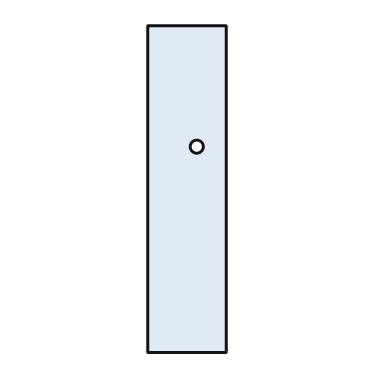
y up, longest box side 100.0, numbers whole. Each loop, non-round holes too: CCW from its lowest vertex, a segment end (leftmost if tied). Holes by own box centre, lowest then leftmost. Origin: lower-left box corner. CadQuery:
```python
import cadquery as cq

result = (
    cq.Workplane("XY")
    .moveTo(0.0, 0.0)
    .lineTo(24.0, 0.0)
    .lineTo(24.0, 100.0)
    .lineTo(0.0, 100.0)
    .close()
    .moveTo(15.0, 63.0)
    .circle(2.0)
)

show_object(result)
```